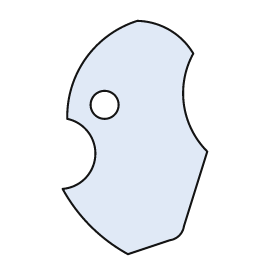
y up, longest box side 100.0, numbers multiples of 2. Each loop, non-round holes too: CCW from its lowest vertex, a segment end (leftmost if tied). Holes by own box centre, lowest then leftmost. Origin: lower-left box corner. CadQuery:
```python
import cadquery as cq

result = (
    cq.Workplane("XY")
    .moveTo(28.0, 0.0)
    .lineTo(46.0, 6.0)
    .threePointArc((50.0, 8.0), (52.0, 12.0))
    .lineTo(62.0, 44.0)
    .threePointArc((52.0, 64.0), (56.0, 86.0))
    .threePointArc((46.0, 96.0), (32.0, 100.0))
    .threePointArc((10.0, 84.0), (2.0, 58.0))
    .threePointArc((14.0, 42.0), (0.0, 28.0))
    .threePointArc((12.0, 12.0), (28.0, 0.0))
    .close()
    .moveTo(18.0, 64.0)
    .circle(6.0)
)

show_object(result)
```